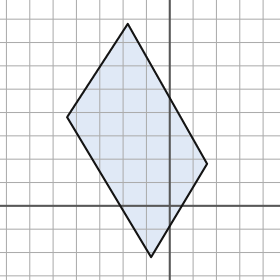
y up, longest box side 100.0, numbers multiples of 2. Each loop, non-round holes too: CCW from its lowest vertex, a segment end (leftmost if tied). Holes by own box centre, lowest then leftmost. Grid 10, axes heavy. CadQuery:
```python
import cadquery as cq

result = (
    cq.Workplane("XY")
    .moveTo(-8.0, -22.0)
    .lineTo(16.0, 18.0)
    .lineTo(-18.0, 78.0)
    .lineTo(-44.0, 38.0)
    .close()
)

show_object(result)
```